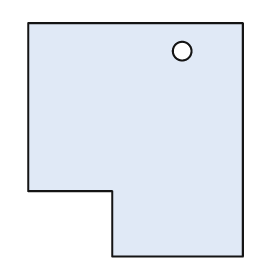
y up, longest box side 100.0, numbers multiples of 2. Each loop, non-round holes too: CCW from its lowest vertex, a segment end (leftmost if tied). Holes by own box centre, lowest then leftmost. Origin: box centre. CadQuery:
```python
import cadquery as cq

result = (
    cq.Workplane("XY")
    .moveTo(-10.0, -50.0)
    .lineTo(46.0, -50.0)
    .lineTo(46.0, 50.0)
    .lineTo(-46.0, 50.0)
    .lineTo(-46.0, -22.0)
    .lineTo(-10.0, -22.0)
    .close()
    .moveTo(20.0, 38.0)
    .circle(4.0)
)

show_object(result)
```